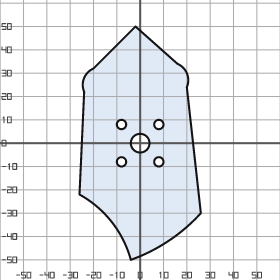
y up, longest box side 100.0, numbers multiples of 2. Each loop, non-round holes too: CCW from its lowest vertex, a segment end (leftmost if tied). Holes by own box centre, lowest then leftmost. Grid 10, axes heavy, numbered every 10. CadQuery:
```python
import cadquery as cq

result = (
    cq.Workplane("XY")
    .moveTo(-4.0, -50.0)
    .threePointArc((12.0, -42.0), (26.0, -30.0))
    .lineTo(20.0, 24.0)
    .threePointArc((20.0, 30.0), (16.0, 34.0))
    .lineTo(-2.0, 50.0)
    .lineTo(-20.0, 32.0)
    .threePointArc((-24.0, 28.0), (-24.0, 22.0))
    .lineTo(-26.0, -22.0)
    .threePointArc((-12.0, -34.0), (-4.0, -50.0))
    .close()
    .moveTo(-8.0, -8.0)
    .circle(2.0)
    .moveTo(8.0, -8.0)
    .circle(2.0)
    .moveTo(0.0, 0.0)
    .circle(4.0)
    .moveTo(-8.0, 8.0)
    .circle(2.0)
    .moveTo(8.0, 8.0)
    .circle(2.0)
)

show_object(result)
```